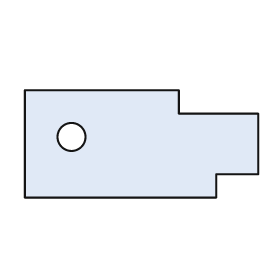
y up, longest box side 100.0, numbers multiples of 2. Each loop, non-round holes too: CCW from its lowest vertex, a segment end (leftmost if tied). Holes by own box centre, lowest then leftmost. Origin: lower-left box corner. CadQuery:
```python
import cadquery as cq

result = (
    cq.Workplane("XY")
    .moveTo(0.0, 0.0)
    .lineTo(82.0, 0.0)
    .lineTo(82.0, 10.0)
    .lineTo(100.0, 10.0)
    .lineTo(100.0, 36.0)
    .lineTo(66.0, 36.0)
    .lineTo(66.0, 46.0)
    .lineTo(0.0, 46.0)
    .close()
    .moveTo(20.0, 26.0)
    .circle(6.0)
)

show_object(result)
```